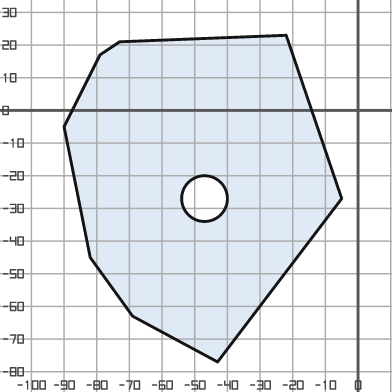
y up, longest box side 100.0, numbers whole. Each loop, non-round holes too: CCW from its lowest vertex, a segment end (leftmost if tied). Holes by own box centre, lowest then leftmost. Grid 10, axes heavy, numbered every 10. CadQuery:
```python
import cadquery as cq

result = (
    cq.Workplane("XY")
    .moveTo(-43.0, -77.0)
    .lineTo(-5.0, -27.0)
    .lineTo(-22.0, 23.0)
    .lineTo(-73.0, 21.0)
    .lineTo(-79.0, 17.0)
    .lineTo(-90.0, -5.0)
    .lineTo(-82.0, -45.0)
    .lineTo(-69.0, -63.0)
    .close()
    .moveTo(-47.0, -27.0)
    .circle(7.0)
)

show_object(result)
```